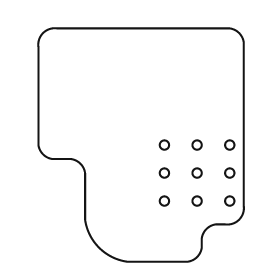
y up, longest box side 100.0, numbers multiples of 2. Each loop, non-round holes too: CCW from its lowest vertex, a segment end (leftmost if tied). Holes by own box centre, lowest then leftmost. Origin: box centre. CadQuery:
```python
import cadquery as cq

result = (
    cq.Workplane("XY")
    .moveTo(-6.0, -50.0)
    .lineTo(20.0, -50.0)
    .threePointArc((24.0, -48.0), (26.0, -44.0))
    .lineTo(26.0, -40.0)
    .threePointArc((28.0, -36.0), (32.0, -34.0))
    .lineTo(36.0, -34.0)
    .threePointArc((42.0, -32.0), (44.0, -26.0))
    .lineTo(44.0, 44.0)
    .threePointArc((42.0, 48.0), (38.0, 50.0))
    .lineTo(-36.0, 50.0)
    .threePointArc((-42.0, 48.0), (-44.0, 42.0))
    .lineTo(-44.0, 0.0)
    .threePointArc((-42.0, -4.0), (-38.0, -6.0))
    .lineTo(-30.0, -6.0)
    .threePointArc((-26.0, -8.0), (-24.0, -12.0))
    .lineTo(-24.0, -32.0)
    .threePointArc((-18.0, -44.0), (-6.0, -50.0))
    .close()
    .moveTo(10.0, -24.0)
    .circle(2.0)
    .moveTo(24.0, -24.0)
    .circle(2.0)
    .moveTo(38.0, -24.0)
    .circle(2.0)
    .moveTo(10.0, -12.0)
    .circle(2.0)
    .moveTo(24.0, -12.0)
    .circle(2.0)
    .moveTo(38.0, -12.0)
    .circle(2.0)
    .moveTo(10.0, 0.0)
    .circle(2.0)
    .moveTo(24.0, 0.0)
    .circle(2.0)
    .moveTo(38.0, 0.0)
    .circle(2.0)
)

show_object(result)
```